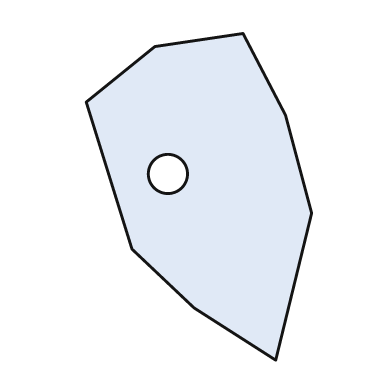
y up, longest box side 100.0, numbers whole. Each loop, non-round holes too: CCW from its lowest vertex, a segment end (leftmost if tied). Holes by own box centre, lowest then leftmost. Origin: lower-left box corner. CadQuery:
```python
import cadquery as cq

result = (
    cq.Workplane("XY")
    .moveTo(58.0, 0.0)
    .lineTo(69.0, 45.0)
    .lineTo(61.0, 75.0)
    .lineTo(48.0, 100.0)
    .lineTo(21.0, 96.0)
    .lineTo(0.0, 79.0)
    .lineTo(14.0, 34.0)
    .lineTo(33.0, 16.0)
    .close()
    .moveTo(25.0, 57.0)
    .circle(6.0)
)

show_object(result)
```